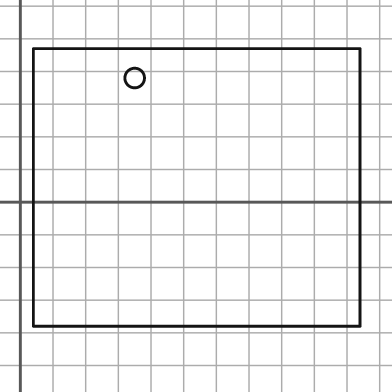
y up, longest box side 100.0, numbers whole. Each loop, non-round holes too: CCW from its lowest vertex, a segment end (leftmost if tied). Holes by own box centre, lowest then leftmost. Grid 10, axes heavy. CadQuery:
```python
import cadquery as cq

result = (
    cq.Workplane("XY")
    .moveTo(4.0, -38.0)
    .lineTo(104.0, -38.0)
    .lineTo(104.0, 47.0)
    .lineTo(4.0, 47.0)
    .close()
    .moveTo(35.0, 38.0)
    .circle(3.0)
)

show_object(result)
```